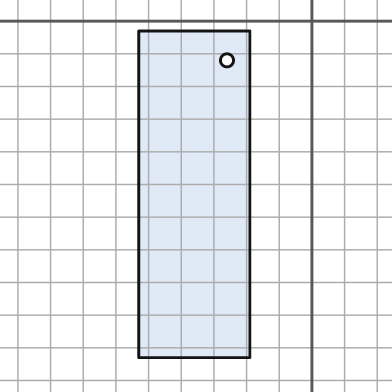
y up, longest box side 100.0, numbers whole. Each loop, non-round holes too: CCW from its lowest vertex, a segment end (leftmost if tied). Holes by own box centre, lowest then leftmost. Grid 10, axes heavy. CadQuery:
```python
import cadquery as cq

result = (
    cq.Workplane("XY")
    .moveTo(-53.0, -103.0)
    .lineTo(-19.0, -103.0)
    .lineTo(-19.0, -3.0)
    .lineTo(-53.0, -3.0)
    .close()
    .moveTo(-26.0, -12.0)
    .circle(2.0)
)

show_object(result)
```